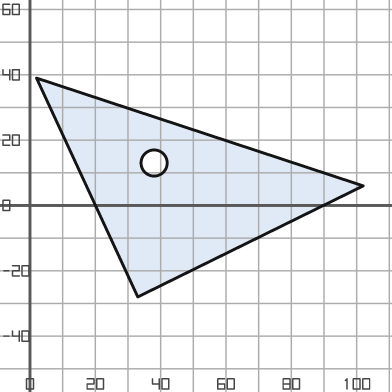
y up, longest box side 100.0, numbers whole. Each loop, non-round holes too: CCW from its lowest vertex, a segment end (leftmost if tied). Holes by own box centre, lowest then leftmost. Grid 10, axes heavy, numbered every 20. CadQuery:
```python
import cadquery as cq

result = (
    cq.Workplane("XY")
    .moveTo(33.0, -28.0)
    .lineTo(102.0, 6.0)
    .lineTo(2.0, 39.0)
    .close()
    .moveTo(38.0, 13.0)
    .circle(4.0)
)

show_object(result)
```